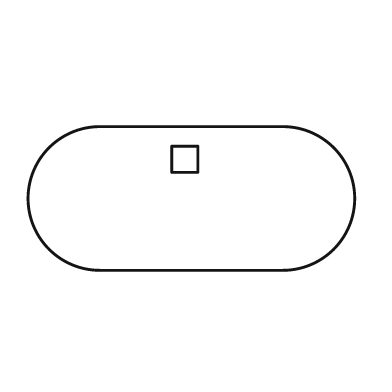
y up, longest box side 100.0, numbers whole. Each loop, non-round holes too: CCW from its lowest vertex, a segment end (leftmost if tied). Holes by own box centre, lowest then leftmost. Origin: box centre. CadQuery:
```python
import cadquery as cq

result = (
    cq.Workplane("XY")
    .moveTo(-28.0, -22.0)
    .lineTo(28.0, -22.0)
    .threePointArc((50.0, 0.0), (28.0, 22.0))
    .lineTo(-28.0, 22.0)
    .threePointArc((-50.0, 0.0), (-28.0, -22.0))
    .close()
    .moveTo(-6.0, 8.0)
    .lineTo(2.0, 8.0)
    .lineTo(2.0, 16.0)
    .lineTo(-6.0, 16.0)
    .close()
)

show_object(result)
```